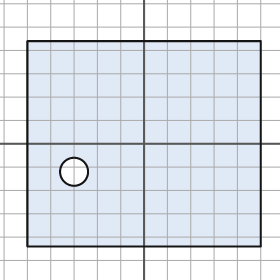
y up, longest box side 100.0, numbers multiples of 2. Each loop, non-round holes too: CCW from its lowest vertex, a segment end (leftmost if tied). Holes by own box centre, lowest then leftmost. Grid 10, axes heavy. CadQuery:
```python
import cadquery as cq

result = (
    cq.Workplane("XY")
    .moveTo(-50.0, -44.0)
    .lineTo(50.0, -44.0)
    .lineTo(50.0, 44.0)
    .lineTo(-50.0, 44.0)
    .close()
    .moveTo(-30.0, -12.0)
    .circle(6.0)
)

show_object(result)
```